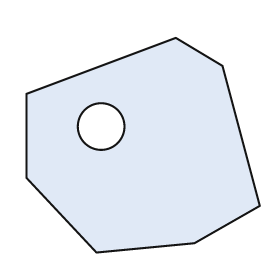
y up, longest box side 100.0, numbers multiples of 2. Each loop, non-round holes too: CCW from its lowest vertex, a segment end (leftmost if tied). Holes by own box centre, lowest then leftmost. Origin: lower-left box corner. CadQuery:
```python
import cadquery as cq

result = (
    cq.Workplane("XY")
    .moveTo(30.0, 0.0)
    .lineTo(72.0, 4.0)
    .lineTo(100.0, 20.0)
    .lineTo(84.0, 80.0)
    .lineTo(64.0, 92.0)
    .lineTo(0.0, 68.0)
    .lineTo(0.0, 32.0)
    .close()
    .moveTo(32.0, 54.0)
    .circle(10.0)
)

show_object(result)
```